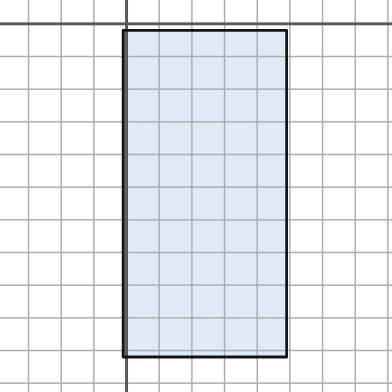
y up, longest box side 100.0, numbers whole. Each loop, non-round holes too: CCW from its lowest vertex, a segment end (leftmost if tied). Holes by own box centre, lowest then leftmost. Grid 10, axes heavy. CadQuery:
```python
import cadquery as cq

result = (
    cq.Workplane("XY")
    .moveTo(-1.0, -102.0)
    .lineTo(49.0, -102.0)
    .lineTo(49.0, -2.0)
    .lineTo(-1.0, -2.0)
    .close()
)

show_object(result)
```